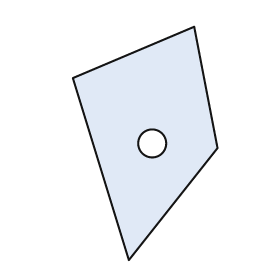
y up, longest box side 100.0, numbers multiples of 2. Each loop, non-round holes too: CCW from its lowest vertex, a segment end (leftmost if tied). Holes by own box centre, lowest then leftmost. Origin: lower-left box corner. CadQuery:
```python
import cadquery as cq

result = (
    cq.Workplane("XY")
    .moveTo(24.0, 0.0)
    .lineTo(62.0, 48.0)
    .lineTo(52.0, 100.0)
    .lineTo(0.0, 78.0)
    .close()
    .moveTo(34.0, 50.0)
    .circle(6.0)
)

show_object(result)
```